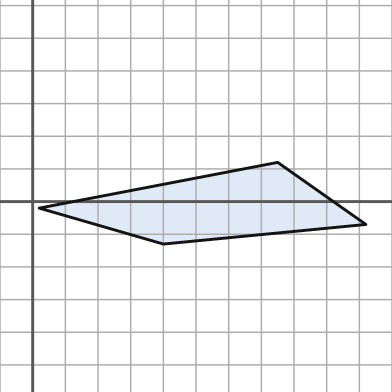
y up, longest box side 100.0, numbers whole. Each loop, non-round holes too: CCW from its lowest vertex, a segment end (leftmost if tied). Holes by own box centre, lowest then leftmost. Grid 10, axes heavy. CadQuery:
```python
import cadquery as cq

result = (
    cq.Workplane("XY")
    .moveTo(40.0, -13.0)
    .lineTo(102.0, -7.0)
    .lineTo(75.0, 12.0)
    .lineTo(2.0, -2.0)
    .close()
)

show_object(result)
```